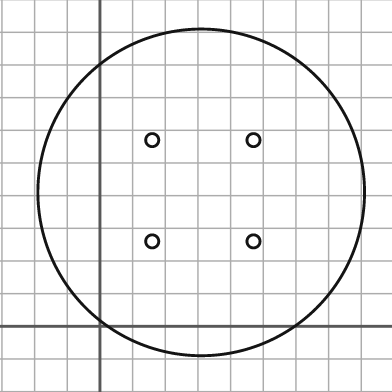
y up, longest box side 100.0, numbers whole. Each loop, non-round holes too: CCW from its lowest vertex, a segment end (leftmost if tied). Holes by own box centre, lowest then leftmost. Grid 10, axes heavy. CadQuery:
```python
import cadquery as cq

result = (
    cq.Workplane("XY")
    .moveTo(31.0, 41.0)
    .circle(50.0)
    .moveTo(16.0, 26.0)
    .circle(2.0)
    .moveTo(47.0, 26.0)
    .circle(2.0)
    .moveTo(16.0, 57.0)
    .circle(2.0)
    .moveTo(47.0, 57.0)
    .circle(2.0)
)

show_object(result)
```